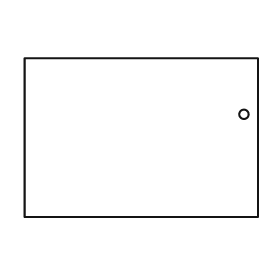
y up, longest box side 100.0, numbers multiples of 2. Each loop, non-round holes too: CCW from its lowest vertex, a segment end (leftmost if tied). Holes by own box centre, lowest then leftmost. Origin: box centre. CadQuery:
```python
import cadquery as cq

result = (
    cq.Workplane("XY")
    .moveTo(-50.0, -34.0)
    .lineTo(50.0, -34.0)
    .lineTo(50.0, 34.0)
    .lineTo(-50.0, 34.0)
    .close()
    .moveTo(44.0, 10.0)
    .circle(2.0)
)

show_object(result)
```